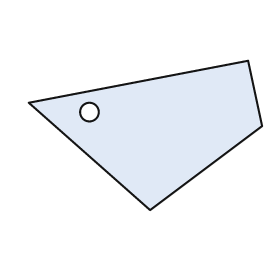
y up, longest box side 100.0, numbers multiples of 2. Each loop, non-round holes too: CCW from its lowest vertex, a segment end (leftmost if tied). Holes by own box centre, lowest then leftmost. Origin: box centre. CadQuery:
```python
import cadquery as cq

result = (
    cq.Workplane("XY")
    .moveTo(2.0, -32.0)
    .lineTo(50.0, 4.0)
    .lineTo(44.0, 32.0)
    .lineTo(-50.0, 14.0)
    .close()
    .moveTo(-24.0, 10.0)
    .circle(4.0)
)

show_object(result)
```